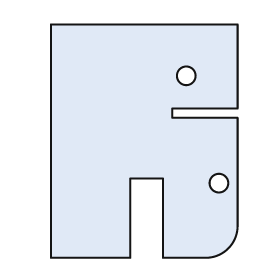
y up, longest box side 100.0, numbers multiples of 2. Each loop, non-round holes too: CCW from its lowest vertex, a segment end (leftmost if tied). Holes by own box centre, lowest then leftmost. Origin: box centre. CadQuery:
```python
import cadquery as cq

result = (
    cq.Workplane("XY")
    .moveTo(-40.0, -50.0)
    .lineTo(-6.0, -50.0)
    .lineTo(-6.0, -16.0)
    .lineTo(8.0, -16.0)
    .lineTo(8.0, -50.0)
    .lineTo(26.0, -50.0)
    .threePointArc((36.0, -46.0), (40.0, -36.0))
    .lineTo(40.0, 10.0)
    .lineTo(12.0, 10.0)
    .lineTo(12.0, 14.0)
    .lineTo(40.0, 14.0)
    .lineTo(40.0, 50.0)
    .lineTo(-40.0, 50.0)
    .close()
    .moveTo(32.0, -18.0)
    .circle(4.0)
    .moveTo(18.0, 28.0)
    .circle(4.0)
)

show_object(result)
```